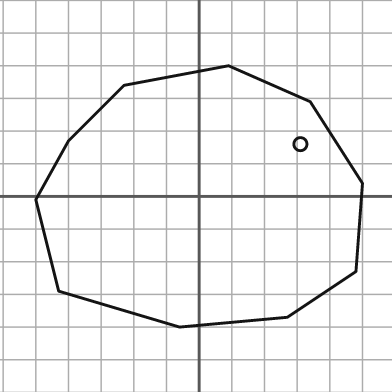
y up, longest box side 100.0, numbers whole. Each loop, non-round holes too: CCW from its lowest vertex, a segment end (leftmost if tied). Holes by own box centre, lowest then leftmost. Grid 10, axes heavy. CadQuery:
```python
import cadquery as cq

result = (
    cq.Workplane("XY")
    .moveTo(-6.0, -40.0)
    .lineTo(27.0, -37.0)
    .lineTo(48.0, -23.0)
    .lineTo(50.0, 4.0)
    .lineTo(34.0, 29.0)
    .lineTo(9.0, 40.0)
    .lineTo(-23.0, 34.0)
    .lineTo(-40.0, 17.0)
    .lineTo(-50.0, -1.0)
    .lineTo(-43.0, -29.0)
    .close()
    .moveTo(31.0, 16.0)
    .circle(2.0)
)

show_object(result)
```